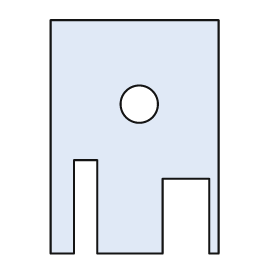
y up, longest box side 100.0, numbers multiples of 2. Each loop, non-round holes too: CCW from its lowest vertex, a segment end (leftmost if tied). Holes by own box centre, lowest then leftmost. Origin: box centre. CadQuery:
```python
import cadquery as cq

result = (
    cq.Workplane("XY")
    .moveTo(-36.0, -50.0)
    .lineTo(-26.0, -50.0)
    .lineTo(-26.0, -10.0)
    .lineTo(-16.0, -10.0)
    .lineTo(-16.0, -50.0)
    .lineTo(12.0, -50.0)
    .lineTo(12.0, -18.0)
    .lineTo(32.0, -18.0)
    .lineTo(32.0, -50.0)
    .lineTo(36.0, -50.0)
    .lineTo(36.0, 50.0)
    .lineTo(-36.0, 50.0)
    .close()
    .moveTo(2.0, 14.0)
    .circle(8.0)
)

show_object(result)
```